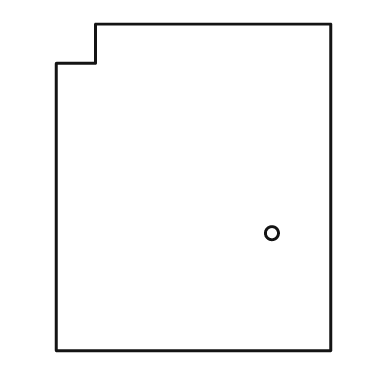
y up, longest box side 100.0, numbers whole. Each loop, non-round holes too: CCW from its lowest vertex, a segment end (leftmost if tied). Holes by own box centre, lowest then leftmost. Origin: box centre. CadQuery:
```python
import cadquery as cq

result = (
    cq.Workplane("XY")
    .moveTo(-42.0, -50.0)
    .lineTo(42.0, -50.0)
    .lineTo(42.0, 50.0)
    .lineTo(-30.0, 50.0)
    .lineTo(-30.0, 38.0)
    .lineTo(-42.0, 38.0)
    .close()
    .moveTo(24.0, -14.0)
    .circle(2.0)
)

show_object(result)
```